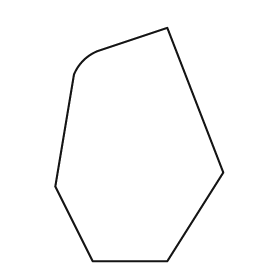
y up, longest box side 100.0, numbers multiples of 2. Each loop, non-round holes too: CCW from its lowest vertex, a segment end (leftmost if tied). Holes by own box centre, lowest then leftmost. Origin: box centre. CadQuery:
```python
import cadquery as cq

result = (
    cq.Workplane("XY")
    .moveTo(-20.0, -50.0)
    .lineTo(12.0, -50.0)
    .lineTo(36.0, -12.0)
    .lineTo(12.0, 50.0)
    .lineTo(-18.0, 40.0)
    .threePointArc((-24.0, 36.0), (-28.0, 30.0))
    .lineTo(-36.0, -18.0)
    .close()
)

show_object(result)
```